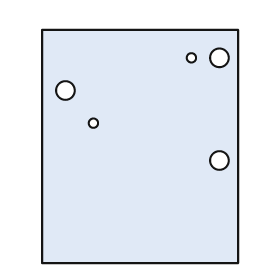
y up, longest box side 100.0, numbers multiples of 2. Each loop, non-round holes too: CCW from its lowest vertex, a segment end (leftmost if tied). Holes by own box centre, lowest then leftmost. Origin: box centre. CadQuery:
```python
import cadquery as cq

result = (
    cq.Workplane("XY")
    .moveTo(-42.0, -50.0)
    .lineTo(42.0, -50.0)
    .lineTo(42.0, 50.0)
    .lineTo(-42.0, 50.0)
    .close()
    .moveTo(34.0, -6.0)
    .circle(4.0)
    .moveTo(-20.0, 10.0)
    .circle(2.0)
    .moveTo(-32.0, 24.0)
    .circle(4.0)
    .moveTo(22.0, 38.0)
    .circle(2.0)
    .moveTo(34.0, 38.0)
    .circle(4.0)
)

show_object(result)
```